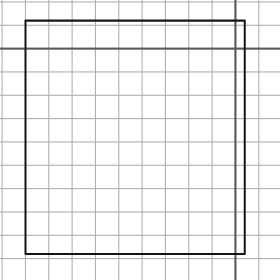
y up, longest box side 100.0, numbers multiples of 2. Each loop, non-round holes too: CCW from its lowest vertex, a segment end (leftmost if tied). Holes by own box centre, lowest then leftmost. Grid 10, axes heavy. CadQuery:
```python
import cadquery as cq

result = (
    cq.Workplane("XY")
    .moveTo(-90.0, -88.0)
    .lineTo(4.0, -88.0)
    .lineTo(4.0, 12.0)
    .lineTo(-90.0, 12.0)
    .close()
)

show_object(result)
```